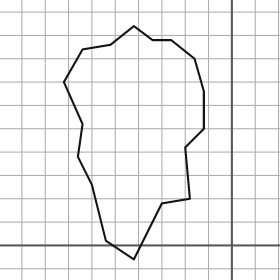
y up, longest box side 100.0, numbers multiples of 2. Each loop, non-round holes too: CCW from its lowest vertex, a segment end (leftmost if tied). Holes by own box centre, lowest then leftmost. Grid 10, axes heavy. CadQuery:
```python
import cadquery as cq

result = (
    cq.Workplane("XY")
    .moveTo(-42.0, -6.0)
    .lineTo(-30.0, 18.0)
    .lineTo(-18.0, 20.0)
    .lineTo(-20.0, 42.0)
    .lineTo(-12.0, 50.0)
    .lineTo(-12.0, 66.0)
    .lineTo(-16.0, 80.0)
    .lineTo(-26.0, 88.0)
    .lineTo(-34.0, 88.0)
    .lineTo(-42.0, 94.0)
    .lineTo(-52.0, 86.0)
    .lineTo(-64.0, 84.0)
    .lineTo(-72.0, 70.0)
    .lineTo(-64.0, 52.0)
    .lineTo(-66.0, 38.0)
    .lineTo(-60.0, 26.0)
    .lineTo(-54.0, 2.0)
    .close()
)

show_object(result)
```